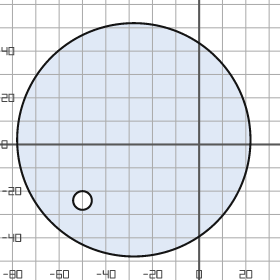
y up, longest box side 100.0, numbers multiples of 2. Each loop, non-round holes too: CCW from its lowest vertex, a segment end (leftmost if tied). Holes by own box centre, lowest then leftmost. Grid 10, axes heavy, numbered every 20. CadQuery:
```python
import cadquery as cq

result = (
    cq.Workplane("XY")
    .moveTo(-28.0, 2.0)
    .circle(50.0)
    .moveTo(-50.0, -24.0)
    .circle(4.0)
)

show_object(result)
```